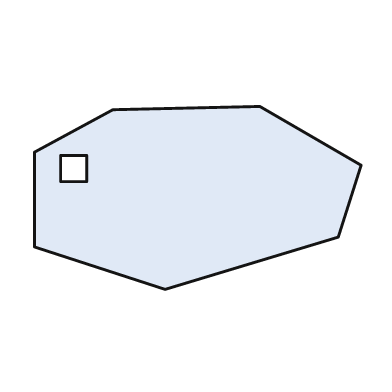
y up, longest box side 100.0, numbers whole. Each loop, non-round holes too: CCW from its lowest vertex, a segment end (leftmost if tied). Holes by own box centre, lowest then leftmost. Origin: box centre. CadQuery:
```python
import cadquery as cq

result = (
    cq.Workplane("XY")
    .moveTo(-10.0, -28.0)
    .lineTo(43.0, -12.0)
    .lineTo(50.0, 10.0)
    .lineTo(19.0, 28.0)
    .lineTo(-26.0, 27.0)
    .lineTo(-50.0, 14.0)
    .lineTo(-50.0, -15.0)
    .close()
    .moveTo(-42.0, 5.0)
    .lineTo(-34.0, 5.0)
    .lineTo(-34.0, 13.0)
    .lineTo(-42.0, 13.0)
    .close()
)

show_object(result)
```